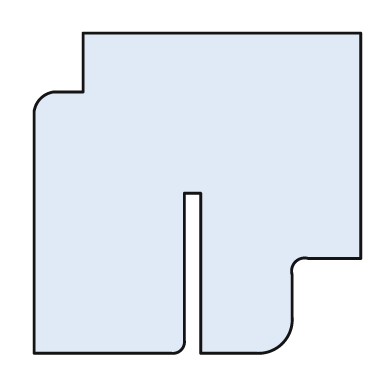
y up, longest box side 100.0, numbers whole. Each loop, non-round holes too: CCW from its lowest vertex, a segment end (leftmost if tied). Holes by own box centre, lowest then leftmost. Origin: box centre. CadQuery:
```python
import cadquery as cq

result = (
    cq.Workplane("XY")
    .moveTo(-50.0, -49.0)
    .lineTo(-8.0, -49.0)
    .threePointArc((-5.0, -48.0), (-4.0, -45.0))
    .lineTo(-4.0, 0.0)
    .lineTo(1.0, 0.0)
    .lineTo(1.0, -49.0)
    .lineTo(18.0, -49.0)
    .threePointArc((26.0, -46.0), (29.0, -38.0))
    .lineTo(29.0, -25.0)
    .threePointArc((30.0, -21.0), (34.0, -20.0))
    .lineTo(50.0, -20.0)
    .lineTo(50.0, 49.0)
    .lineTo(-35.0, 49.0)
    .lineTo(-35.0, 31.0)
    .lineTo(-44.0, 31.0)
    .threePointArc((-48.0, 29.0), (-50.0, 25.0))
    .close()
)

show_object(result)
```